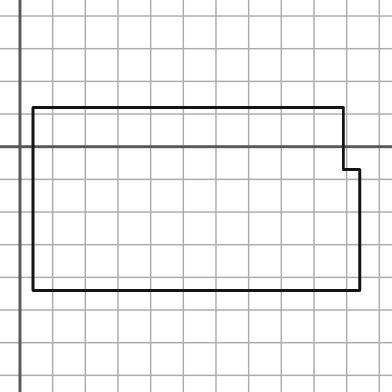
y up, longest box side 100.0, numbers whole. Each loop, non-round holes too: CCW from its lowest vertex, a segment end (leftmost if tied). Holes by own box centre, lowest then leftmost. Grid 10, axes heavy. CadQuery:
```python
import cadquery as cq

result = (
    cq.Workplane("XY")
    .moveTo(4.0, -44.0)
    .lineTo(104.0, -44.0)
    .lineTo(104.0, -7.0)
    .lineTo(99.0, -7.0)
    .lineTo(99.0, 12.0)
    .lineTo(4.0, 12.0)
    .close()
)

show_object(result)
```